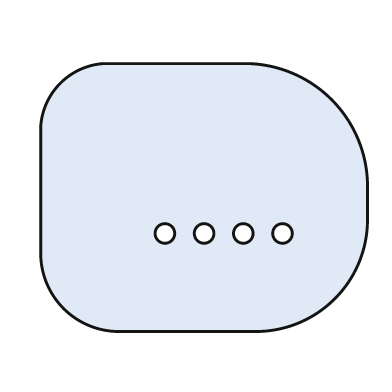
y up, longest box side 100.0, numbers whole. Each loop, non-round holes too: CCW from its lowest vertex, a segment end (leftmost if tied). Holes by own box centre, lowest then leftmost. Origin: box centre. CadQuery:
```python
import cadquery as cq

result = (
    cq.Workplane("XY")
    .moveTo(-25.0, -41.0)
    .lineTo(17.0, -41.0)
    .threePointArc((40.0, -31.0), (50.0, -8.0))
    .lineTo(50.0, 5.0)
    .threePointArc((39.0, 30.0), (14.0, 41.0))
    .lineTo(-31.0, 41.0)
    .threePointArc((-44.0, 35.0), (-50.0, 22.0))
    .lineTo(-50.0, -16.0)
    .threePointArc((-43.0, -34.0), (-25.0, -41.0))
    .close()
    .moveTo(-12.0, -11.0)
    .circle(3.0)
    .moveTo(0.0, -11.0)
    .circle(3.0)
    .moveTo(12.0, -11.0)
    .circle(3.0)
    .moveTo(24.0, -11.0)
    .circle(3.0)
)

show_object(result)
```